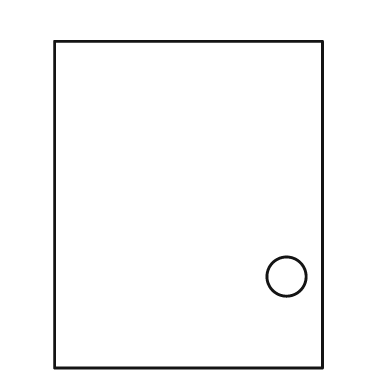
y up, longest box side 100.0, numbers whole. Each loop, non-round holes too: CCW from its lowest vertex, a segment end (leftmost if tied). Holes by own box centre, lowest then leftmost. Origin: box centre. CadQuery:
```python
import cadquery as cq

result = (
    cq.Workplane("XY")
    .moveTo(-41.0, -50.0)
    .lineTo(41.0, -50.0)
    .lineTo(41.0, 50.0)
    .lineTo(-41.0, 50.0)
    .close()
    .moveTo(30.0, -22.0)
    .circle(6.0)
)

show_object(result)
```